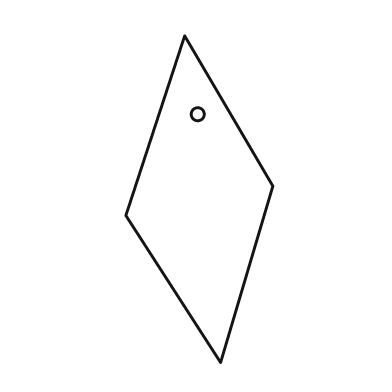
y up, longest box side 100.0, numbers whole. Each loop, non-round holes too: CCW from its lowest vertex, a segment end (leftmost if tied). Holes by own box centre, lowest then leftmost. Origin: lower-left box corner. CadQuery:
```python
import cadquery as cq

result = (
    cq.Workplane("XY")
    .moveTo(29.0, 0.0)
    .lineTo(45.0, 54.0)
    .lineTo(18.0, 100.0)
    .lineTo(0.0, 45.0)
    .close()
    .moveTo(22.0, 76.0)
    .circle(2.0)
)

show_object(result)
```